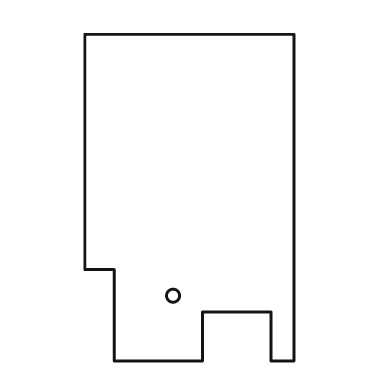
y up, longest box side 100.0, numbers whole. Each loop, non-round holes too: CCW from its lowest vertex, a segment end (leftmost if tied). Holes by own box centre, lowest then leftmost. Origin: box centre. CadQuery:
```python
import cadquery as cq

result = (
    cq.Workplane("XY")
    .moveTo(-23.0, -50.0)
    .lineTo(4.0, -50.0)
    .lineTo(4.0, -35.0)
    .lineTo(25.0, -35.0)
    .lineTo(25.0, -50.0)
    .lineTo(32.0, -50.0)
    .lineTo(32.0, 50.0)
    .lineTo(-32.0, 50.0)
    .lineTo(-32.0, -22.0)
    .lineTo(-23.0, -22.0)
    .close()
    .moveTo(-5.0, -30.0)
    .circle(2.0)
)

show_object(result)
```